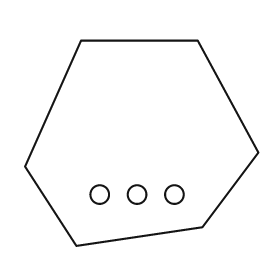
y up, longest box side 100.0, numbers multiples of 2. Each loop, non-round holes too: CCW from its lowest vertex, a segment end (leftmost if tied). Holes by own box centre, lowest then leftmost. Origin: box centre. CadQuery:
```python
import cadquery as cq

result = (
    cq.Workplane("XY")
    .moveTo(-28.0, -44.0)
    .lineTo(26.0, -36.0)
    .lineTo(50.0, -4.0)
    .lineTo(24.0, 44.0)
    .lineTo(-26.0, 44.0)
    .lineTo(-50.0, -10.0)
    .close()
    .moveTo(-18.0, -22.0)
    .circle(4.0)
    .moveTo(-2.0, -22.0)
    .circle(4.0)
    .moveTo(14.0, -22.0)
    .circle(4.0)
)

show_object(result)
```